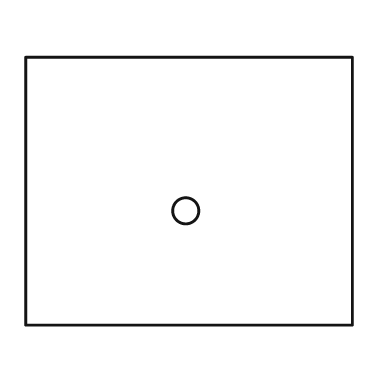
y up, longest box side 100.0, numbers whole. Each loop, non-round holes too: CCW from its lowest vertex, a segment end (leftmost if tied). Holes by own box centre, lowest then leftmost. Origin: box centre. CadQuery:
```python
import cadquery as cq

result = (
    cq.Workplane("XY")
    .moveTo(-50.0, -41.0)
    .lineTo(50.0, -41.0)
    .lineTo(50.0, 41.0)
    .lineTo(-50.0, 41.0)
    .close()
    .moveTo(-1.0, -6.0)
    .circle(4.0)
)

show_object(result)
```